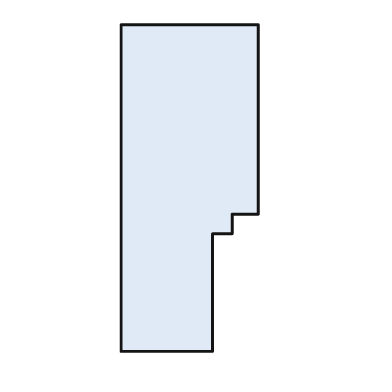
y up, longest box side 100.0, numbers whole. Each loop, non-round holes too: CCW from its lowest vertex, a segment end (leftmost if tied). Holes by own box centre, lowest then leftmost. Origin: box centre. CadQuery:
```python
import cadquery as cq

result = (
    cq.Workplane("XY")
    .moveTo(-21.0, -50.0)
    .lineTo(7.0, -50.0)
    .lineTo(7.0, -14.0)
    .lineTo(13.0, -14.0)
    .lineTo(13.0, -8.0)
    .lineTo(21.0, -8.0)
    .lineTo(21.0, 50.0)
    .lineTo(-21.0, 50.0)
    .close()
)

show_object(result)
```